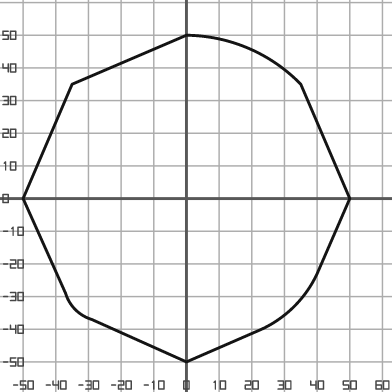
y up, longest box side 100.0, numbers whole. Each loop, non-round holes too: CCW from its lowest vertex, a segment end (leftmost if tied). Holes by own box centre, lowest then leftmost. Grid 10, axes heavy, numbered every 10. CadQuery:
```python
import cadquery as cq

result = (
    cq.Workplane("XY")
    .moveTo(0.0, -50.0)
    .lineTo(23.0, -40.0)
    .threePointArc((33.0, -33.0), (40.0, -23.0))
    .lineTo(50.0, 0.0)
    .lineTo(35.0, 35.0)
    .threePointArc((19.0, 46.0), (0.0, 50.0))
    .lineTo(-35.0, 35.0)
    .lineTo(-50.0, 0.0)
    .lineTo(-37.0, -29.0)
    .threePointArc((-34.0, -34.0), (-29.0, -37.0))
    .close()
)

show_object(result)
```